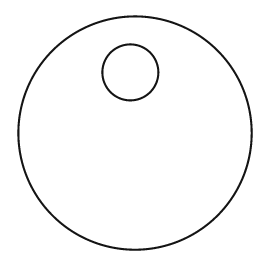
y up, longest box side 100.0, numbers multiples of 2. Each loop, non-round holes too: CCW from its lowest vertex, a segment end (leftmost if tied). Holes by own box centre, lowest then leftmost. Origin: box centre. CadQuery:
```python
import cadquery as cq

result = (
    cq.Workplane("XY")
    .moveTo(0.0, 0.0)
    .circle(50.0)
    .moveTo(-2.0, 26.0)
    .circle(12.0)
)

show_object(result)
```